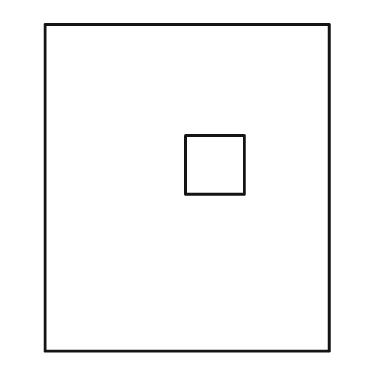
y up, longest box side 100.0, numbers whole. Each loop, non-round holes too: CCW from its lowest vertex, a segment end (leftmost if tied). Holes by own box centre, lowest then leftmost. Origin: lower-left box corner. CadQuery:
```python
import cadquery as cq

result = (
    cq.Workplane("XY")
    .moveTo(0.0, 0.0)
    .lineTo(87.0, 0.0)
    .lineTo(87.0, 100.0)
    .lineTo(0.0, 100.0)
    .close()
    .moveTo(43.0, 48.0)
    .lineTo(61.0, 48.0)
    .lineTo(61.0, 66.0)
    .lineTo(43.0, 66.0)
    .close()
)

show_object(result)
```